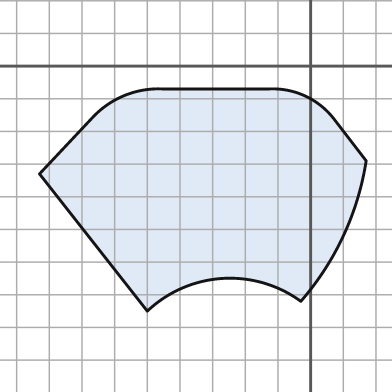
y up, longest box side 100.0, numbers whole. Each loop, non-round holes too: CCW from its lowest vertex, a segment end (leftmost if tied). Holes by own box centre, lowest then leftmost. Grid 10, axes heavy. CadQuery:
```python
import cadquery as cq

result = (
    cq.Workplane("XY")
    .moveTo(-50.0, -75.0)
    .threePointArc((-27.0, -65.0), (-3.0, -72.0))
    .threePointArc((10.0, -52.0), (17.0, -29.0))
    .lineTo(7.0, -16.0)
    .threePointArc((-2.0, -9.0), (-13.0, -7.0))
    .lineTo(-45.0, -7.0)
    .threePointArc((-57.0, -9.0), (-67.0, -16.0))
    .lineTo(-83.0, -33.0)
    .close()
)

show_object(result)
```